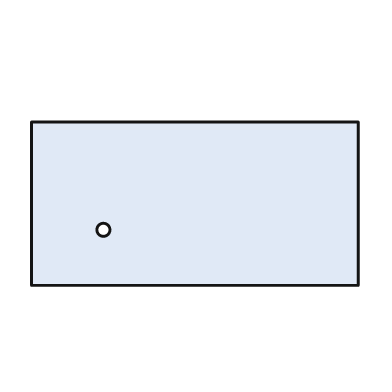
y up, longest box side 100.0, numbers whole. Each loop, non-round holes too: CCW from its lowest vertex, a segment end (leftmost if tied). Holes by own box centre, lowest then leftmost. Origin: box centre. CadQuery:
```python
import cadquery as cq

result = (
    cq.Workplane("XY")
    .moveTo(-50.0, -25.0)
    .lineTo(50.0, -25.0)
    .lineTo(50.0, 25.0)
    .lineTo(-50.0, 25.0)
    .close()
    .moveTo(-28.0, -8.0)
    .circle(2.0)
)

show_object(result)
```